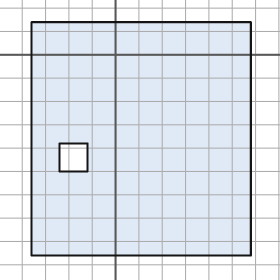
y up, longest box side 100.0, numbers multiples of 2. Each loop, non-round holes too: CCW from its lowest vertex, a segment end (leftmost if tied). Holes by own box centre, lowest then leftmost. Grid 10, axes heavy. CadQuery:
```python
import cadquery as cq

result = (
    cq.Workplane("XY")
    .moveTo(-36.0, -86.0)
    .lineTo(58.0, -86.0)
    .lineTo(58.0, 14.0)
    .lineTo(-36.0, 14.0)
    .close()
    .moveTo(-24.0, -50.0)
    .lineTo(-12.0, -50.0)
    .lineTo(-12.0, -38.0)
    .lineTo(-24.0, -38.0)
    .close()
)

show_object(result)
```